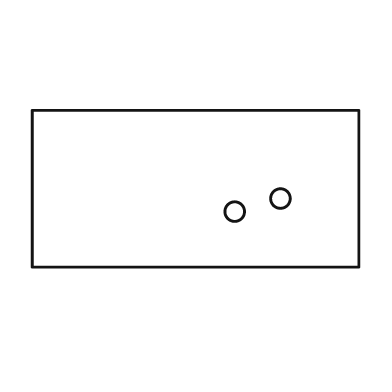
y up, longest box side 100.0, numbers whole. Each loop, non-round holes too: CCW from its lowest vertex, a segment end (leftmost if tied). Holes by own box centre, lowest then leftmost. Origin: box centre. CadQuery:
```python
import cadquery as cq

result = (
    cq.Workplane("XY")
    .moveTo(-50.0, -24.0)
    .lineTo(50.0, -24.0)
    .lineTo(50.0, 24.0)
    .lineTo(-50.0, 24.0)
    .close()
    .moveTo(12.0, -7.0)
    .circle(3.0)
    .moveTo(26.0, -3.0)
    .circle(3.0)
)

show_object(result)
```